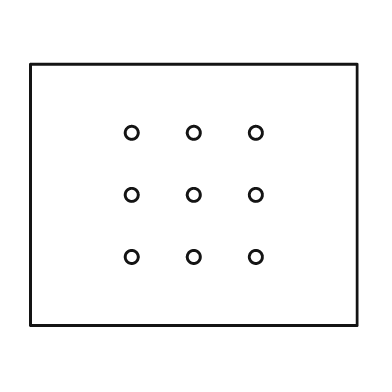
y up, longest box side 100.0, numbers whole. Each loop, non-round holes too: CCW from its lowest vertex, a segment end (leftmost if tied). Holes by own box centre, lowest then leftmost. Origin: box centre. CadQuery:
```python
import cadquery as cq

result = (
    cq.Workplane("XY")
    .moveTo(-50.0, -40.0)
    .lineTo(50.0, -40.0)
    .lineTo(50.0, 40.0)
    .lineTo(-50.0, 40.0)
    .close()
    .moveTo(-19.0, -19.0)
    .circle(2.0)
    .moveTo(0.0, -19.0)
    .circle(2.0)
    .moveTo(19.0, -19.0)
    .circle(2.0)
    .moveTo(-19.0, 0.0)
    .circle(2.0)
    .moveTo(0.0, 0.0)
    .circle(2.0)
    .moveTo(19.0, 0.0)
    .circle(2.0)
    .moveTo(-19.0, 19.0)
    .circle(2.0)
    .moveTo(0.0, 19.0)
    .circle(2.0)
    .moveTo(19.0, 19.0)
    .circle(2.0)
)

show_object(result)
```